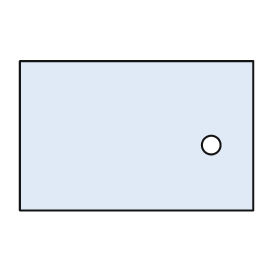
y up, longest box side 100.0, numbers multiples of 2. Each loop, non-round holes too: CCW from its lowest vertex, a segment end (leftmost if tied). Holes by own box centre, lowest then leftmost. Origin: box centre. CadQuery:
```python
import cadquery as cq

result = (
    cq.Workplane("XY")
    .moveTo(-50.0, -32.0)
    .lineTo(50.0, -32.0)
    .lineTo(50.0, 32.0)
    .lineTo(-50.0, 32.0)
    .close()
    .moveTo(32.0, -4.0)
    .circle(4.0)
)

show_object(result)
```